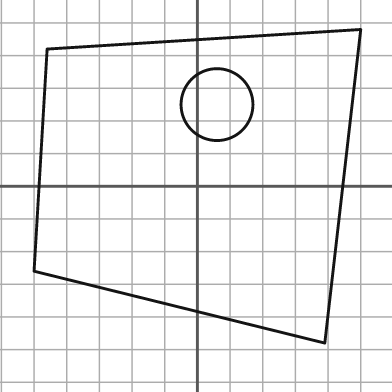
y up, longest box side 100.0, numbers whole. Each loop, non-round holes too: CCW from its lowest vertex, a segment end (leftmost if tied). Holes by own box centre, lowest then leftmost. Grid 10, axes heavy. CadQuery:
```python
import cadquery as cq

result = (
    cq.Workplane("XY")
    .moveTo(39.0, -48.0)
    .lineTo(50.0, 48.0)
    .lineTo(-46.0, 42.0)
    .lineTo(-50.0, -26.0)
    .close()
    .moveTo(6.0, 25.0)
    .circle(11.0)
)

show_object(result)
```